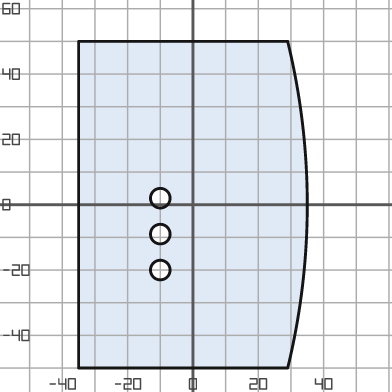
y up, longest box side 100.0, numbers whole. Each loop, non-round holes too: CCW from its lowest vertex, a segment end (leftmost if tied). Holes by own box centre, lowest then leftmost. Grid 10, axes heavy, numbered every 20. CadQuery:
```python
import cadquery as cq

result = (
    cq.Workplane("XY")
    .moveTo(-35.0, -50.0)
    .lineTo(29.0, -50.0)
    .threePointArc((35.0, 0.0), (29.0, 50.0))
    .lineTo(-35.0, 50.0)
    .close()
    .moveTo(-10.0, -20.0)
    .circle(3.0)
    .moveTo(-10.0, -9.0)
    .circle(3.0)
    .moveTo(-10.0, 2.0)
    .circle(3.0)
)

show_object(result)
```